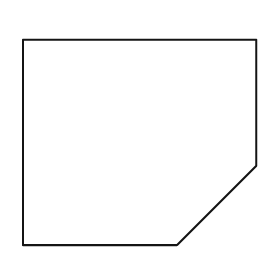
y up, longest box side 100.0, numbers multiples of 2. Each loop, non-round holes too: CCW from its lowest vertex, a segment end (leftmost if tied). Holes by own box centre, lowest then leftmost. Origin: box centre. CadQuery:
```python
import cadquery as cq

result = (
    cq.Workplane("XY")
    .moveTo(-50.0, -44.0)
    .lineTo(16.0, -44.0)
    .lineTo(50.0, -10.0)
    .lineTo(50.0, 44.0)
    .lineTo(-50.0, 44.0)
    .close()
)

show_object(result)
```